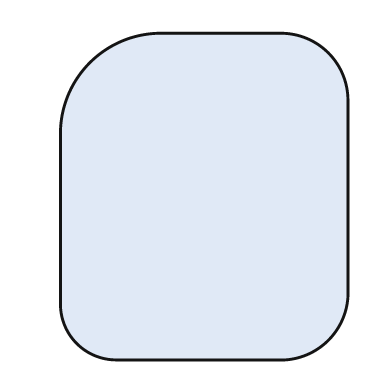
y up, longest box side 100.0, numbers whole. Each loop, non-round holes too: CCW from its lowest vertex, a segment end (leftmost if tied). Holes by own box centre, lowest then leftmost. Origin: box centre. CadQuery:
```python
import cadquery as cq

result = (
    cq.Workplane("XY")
    .moveTo(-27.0, -50.0)
    .lineTo(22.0, -50.0)
    .threePointArc((38.0, -44.0), (44.0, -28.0))
    .lineTo(44.0, 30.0)
    .threePointArc((38.0, 44.0), (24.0, 50.0))
    .lineTo(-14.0, 50.0)
    .threePointArc((-35.0, 41.0), (-44.0, 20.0))
    .lineTo(-44.0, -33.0)
    .threePointArc((-39.0, -45.0), (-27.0, -50.0))
    .close()
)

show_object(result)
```